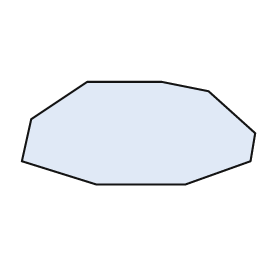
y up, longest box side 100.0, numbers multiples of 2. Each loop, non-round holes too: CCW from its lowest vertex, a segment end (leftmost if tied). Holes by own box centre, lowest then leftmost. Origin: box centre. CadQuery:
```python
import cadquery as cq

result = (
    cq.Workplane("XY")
    .moveTo(-18.0, -22.0)
    .lineTo(20.0, -22.0)
    .lineTo(48.0, -12.0)
    .lineTo(50.0, 0.0)
    .lineTo(30.0, 18.0)
    .lineTo(10.0, 22.0)
    .lineTo(-22.0, 22.0)
    .lineTo(-46.0, 6.0)
    .lineTo(-50.0, -12.0)
    .close()
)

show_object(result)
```